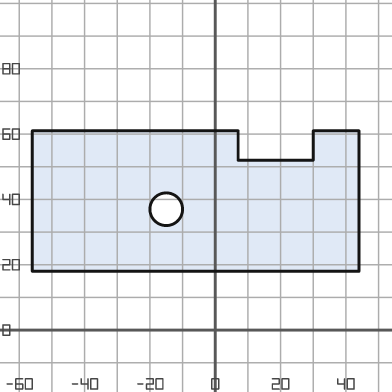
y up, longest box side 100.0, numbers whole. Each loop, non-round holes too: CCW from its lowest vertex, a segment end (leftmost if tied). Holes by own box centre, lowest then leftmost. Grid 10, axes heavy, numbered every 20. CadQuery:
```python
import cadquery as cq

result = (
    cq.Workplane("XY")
    .moveTo(-56.0, 18.0)
    .lineTo(44.0, 18.0)
    .lineTo(44.0, 61.0)
    .lineTo(30.0, 61.0)
    .lineTo(30.0, 52.0)
    .lineTo(7.0, 52.0)
    .lineTo(7.0, 61.0)
    .lineTo(-56.0, 61.0)
    .close()
    .moveTo(-15.0, 37.0)
    .circle(5.0)
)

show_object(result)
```